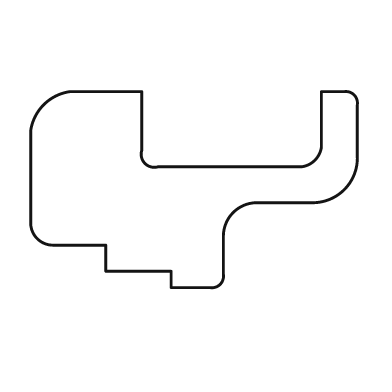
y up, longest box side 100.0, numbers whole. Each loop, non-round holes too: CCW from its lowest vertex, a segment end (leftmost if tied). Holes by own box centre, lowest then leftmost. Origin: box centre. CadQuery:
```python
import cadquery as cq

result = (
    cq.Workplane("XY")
    .moveTo(-7.0, -30.0)
    .lineTo(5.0, -30.0)
    .threePointArc((8.0, -29.0), (9.0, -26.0))
    .lineTo(9.0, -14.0)
    .threePointArc((12.0, -7.0), (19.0, -4.0))
    .lineTo(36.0, -4.0)
    .threePointArc((46.0, 0.0), (50.0, 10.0))
    .lineTo(50.0, 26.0)
    .threePointArc((49.0, 29.0), (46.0, 30.0))
    .lineTo(39.0, 30.0)
    .lineTo(39.0, 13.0)
    .threePointArc((37.0, 9.0), (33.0, 7.0))
    .lineTo(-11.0, 7.0)
    .threePointArc((-15.0, 8.0), (-16.0, 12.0))
    .lineTo(-16.0, 30.0)
    .lineTo(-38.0, 30.0)
    .threePointArc((-46.0, 26.0), (-50.0, 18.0))
    .lineTo(-50.0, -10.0)
    .threePointArc((-48.0, -15.0), (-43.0, -17.0))
    .lineTo(-27.0, -17.0)
    .lineTo(-27.0, -25.0)
    .lineTo(-7.0, -25.0)
    .close()
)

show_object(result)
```